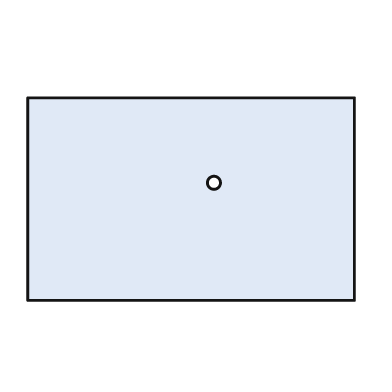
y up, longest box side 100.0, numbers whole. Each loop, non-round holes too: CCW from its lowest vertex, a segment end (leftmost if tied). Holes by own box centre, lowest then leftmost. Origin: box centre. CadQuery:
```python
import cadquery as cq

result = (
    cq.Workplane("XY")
    .moveTo(-50.0, -31.0)
    .lineTo(50.0, -31.0)
    .lineTo(50.0, 31.0)
    .lineTo(-50.0, 31.0)
    .close()
    .moveTo(7.0, 5.0)
    .circle(2.0)
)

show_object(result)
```